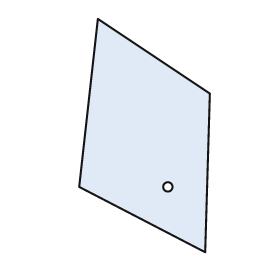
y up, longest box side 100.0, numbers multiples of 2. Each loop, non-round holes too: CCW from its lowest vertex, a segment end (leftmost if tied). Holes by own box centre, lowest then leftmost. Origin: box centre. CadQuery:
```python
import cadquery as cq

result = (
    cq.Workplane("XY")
    .moveTo(26.0, -50.0)
    .lineTo(28.0, 18.0)
    .lineTo(-20.0, 50.0)
    .lineTo(-28.0, -22.0)
    .close()
    .moveTo(10.0, -22.0)
    .circle(2.0)
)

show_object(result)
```